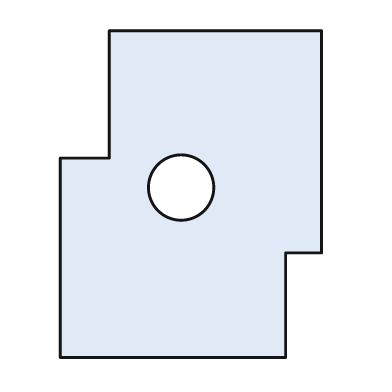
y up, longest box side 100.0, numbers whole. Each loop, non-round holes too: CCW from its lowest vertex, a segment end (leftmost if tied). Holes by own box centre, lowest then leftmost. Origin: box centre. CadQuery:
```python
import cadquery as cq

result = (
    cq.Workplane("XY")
    .moveTo(-40.0, -50.0)
    .lineTo(29.0, -50.0)
    .lineTo(29.0, -18.0)
    .lineTo(40.0, -18.0)
    .lineTo(40.0, 50.0)
    .lineTo(-25.0, 50.0)
    .lineTo(-25.0, 11.0)
    .lineTo(-40.0, 11.0)
    .close()
    .moveTo(-3.0, 2.0)
    .circle(10.0)
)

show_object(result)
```